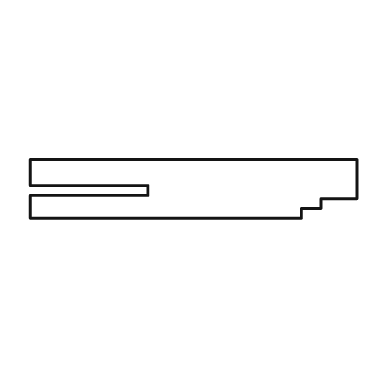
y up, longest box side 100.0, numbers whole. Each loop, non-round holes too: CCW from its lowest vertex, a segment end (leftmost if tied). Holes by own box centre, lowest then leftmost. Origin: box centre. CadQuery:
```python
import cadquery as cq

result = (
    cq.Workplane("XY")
    .moveTo(-50.0, -9.0)
    .lineTo(33.0, -9.0)
    .lineTo(33.0, -6.0)
    .lineTo(39.0, -6.0)
    .lineTo(39.0, -3.0)
    .lineTo(50.0, -3.0)
    .lineTo(50.0, 9.0)
    .lineTo(-50.0, 9.0)
    .lineTo(-50.0, 1.0)
    .lineTo(-14.0, 1.0)
    .lineTo(-14.0, -2.0)
    .lineTo(-50.0, -2.0)
    .close()
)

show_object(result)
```